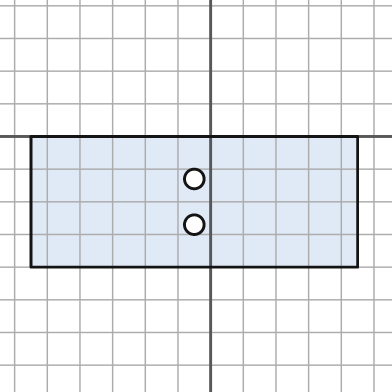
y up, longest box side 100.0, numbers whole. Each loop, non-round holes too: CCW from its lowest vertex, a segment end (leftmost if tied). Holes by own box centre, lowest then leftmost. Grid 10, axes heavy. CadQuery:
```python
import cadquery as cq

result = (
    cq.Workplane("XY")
    .moveTo(-55.0, -40.0)
    .lineTo(45.0, -40.0)
    .lineTo(45.0, 0.0)
    .lineTo(-55.0, 0.0)
    .close()
    .moveTo(-5.0, -27.0)
    .circle(3.0)
    .moveTo(-5.0, -13.0)
    .circle(3.0)
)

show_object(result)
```